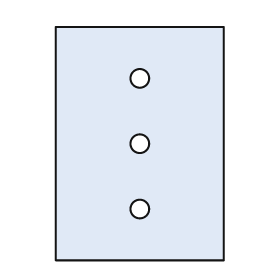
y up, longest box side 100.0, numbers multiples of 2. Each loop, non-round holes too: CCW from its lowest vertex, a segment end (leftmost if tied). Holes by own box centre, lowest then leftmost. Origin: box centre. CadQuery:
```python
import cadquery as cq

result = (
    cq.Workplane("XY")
    .moveTo(-36.0, -50.0)
    .lineTo(36.0, -50.0)
    .lineTo(36.0, 50.0)
    .lineTo(-36.0, 50.0)
    .close()
    .moveTo(0.0, -28.0)
    .circle(4.0)
    .moveTo(0.0, 0.0)
    .circle(4.0)
    .moveTo(0.0, 28.0)
    .circle(4.0)
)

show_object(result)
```